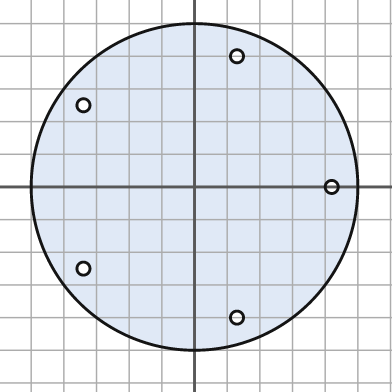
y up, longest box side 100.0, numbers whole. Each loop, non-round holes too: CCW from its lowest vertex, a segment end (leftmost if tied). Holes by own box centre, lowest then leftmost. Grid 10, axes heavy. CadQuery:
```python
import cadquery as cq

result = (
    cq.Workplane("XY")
    .moveTo(0.0, 0.0)
    .circle(50.0)
    .moveTo(13.0, -40.0)
    .circle(2.0)
    .moveTo(-34.0, -25.0)
    .circle(2.0)
    .moveTo(42.0, 0.0)
    .circle(2.0)
    .moveTo(-34.0, 25.0)
    .circle(2.0)
    .moveTo(13.0, 40.0)
    .circle(2.0)
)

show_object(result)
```